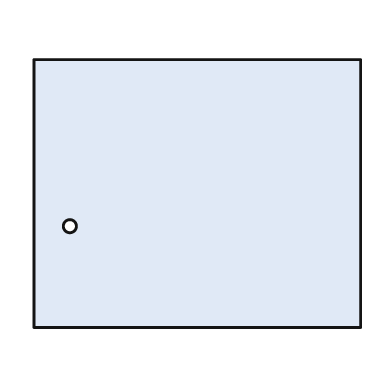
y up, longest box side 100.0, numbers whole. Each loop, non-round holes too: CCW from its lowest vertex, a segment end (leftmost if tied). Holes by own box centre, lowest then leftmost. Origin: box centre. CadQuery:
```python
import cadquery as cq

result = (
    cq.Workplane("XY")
    .moveTo(-50.0, -41.0)
    .lineTo(50.0, -41.0)
    .lineTo(50.0, 41.0)
    .lineTo(-50.0, 41.0)
    .close()
    .moveTo(-39.0, -10.0)
    .circle(2.0)
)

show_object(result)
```